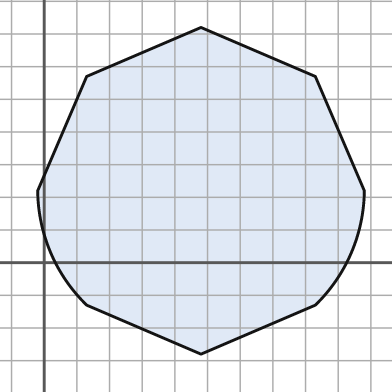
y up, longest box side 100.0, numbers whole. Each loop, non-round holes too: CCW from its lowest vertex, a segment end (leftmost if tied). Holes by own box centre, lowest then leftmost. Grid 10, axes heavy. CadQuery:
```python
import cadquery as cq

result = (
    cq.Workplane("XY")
    .moveTo(48.0, -28.0)
    .lineTo(83.0, -13.0)
    .threePointArc((94.0, 3.0), (98.0, 22.0))
    .lineTo(83.0, 57.0)
    .lineTo(48.0, 72.0)
    .lineTo(13.0, 57.0)
    .lineTo(-2.0, 22.0)
    .threePointArc((2.0, 3.0), (13.0, -13.0))
    .close()
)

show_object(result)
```